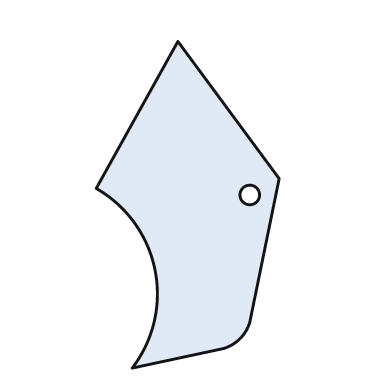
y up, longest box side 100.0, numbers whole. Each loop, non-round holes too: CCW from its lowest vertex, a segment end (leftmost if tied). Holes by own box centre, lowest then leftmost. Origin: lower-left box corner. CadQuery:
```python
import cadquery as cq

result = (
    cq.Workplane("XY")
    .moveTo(11.0, 0.0)
    .lineTo(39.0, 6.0)
    .threePointArc((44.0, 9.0), (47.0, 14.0))
    .lineTo(56.0, 58.0)
    .lineTo(25.0, 100.0)
    .lineTo(0.0, 55.0)
    .threePointArc((18.0, 30.0), (11.0, 0.0))
    .close()
    .moveTo(47.0, 53.0)
    .circle(3.0)
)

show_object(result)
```